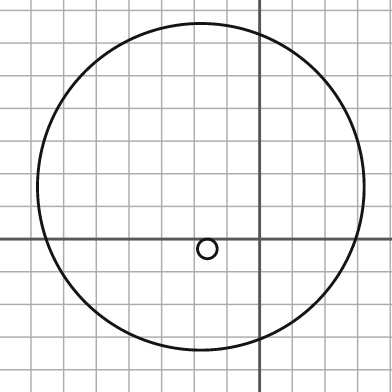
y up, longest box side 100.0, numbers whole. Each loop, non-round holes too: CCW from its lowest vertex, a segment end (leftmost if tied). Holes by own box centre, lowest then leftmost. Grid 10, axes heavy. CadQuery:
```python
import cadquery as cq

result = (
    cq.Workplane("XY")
    .moveTo(-18.0, 16.0)
    .circle(50.0)
    .moveTo(-16.0, -3.0)
    .circle(3.0)
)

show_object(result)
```